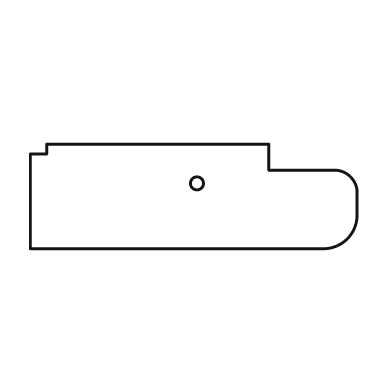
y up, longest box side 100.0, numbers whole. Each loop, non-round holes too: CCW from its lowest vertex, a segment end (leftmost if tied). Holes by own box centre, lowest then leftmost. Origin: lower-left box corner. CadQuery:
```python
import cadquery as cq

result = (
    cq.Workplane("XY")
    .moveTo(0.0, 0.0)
    .lineTo(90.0, 0.0)
    .threePointArc((97.0, 3.0), (100.0, 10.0))
    .lineTo(100.0, 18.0)
    .threePointArc((98.0, 22.0), (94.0, 24.0))
    .lineTo(73.0, 24.0)
    .lineTo(73.0, 32.0)
    .lineTo(5.0, 32.0)
    .lineTo(5.0, 29.0)
    .lineTo(0.0, 29.0)
    .close()
    .moveTo(51.0, 20.0)
    .circle(2.0)
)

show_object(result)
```